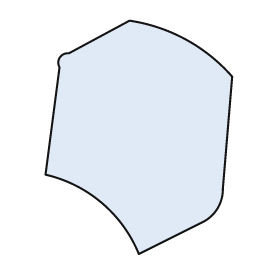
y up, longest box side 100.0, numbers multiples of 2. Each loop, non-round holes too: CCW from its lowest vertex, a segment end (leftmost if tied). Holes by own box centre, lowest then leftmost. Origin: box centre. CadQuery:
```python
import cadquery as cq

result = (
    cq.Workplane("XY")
    .moveTo(0.0, -50.0)
    .lineTo(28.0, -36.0)
    .threePointArc((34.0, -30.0), (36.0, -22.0))
    .lineTo(40.0, 26.0)
    .threePointArc((20.0, 42.0), (-4.0, 50.0))
    .lineTo(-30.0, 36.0)
    .threePointArc((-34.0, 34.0), (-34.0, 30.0))
    .lineTo(-40.0, -16.0)
    .threePointArc((-16.0, -28.0), (0.0, -50.0))
    .close()
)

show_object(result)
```